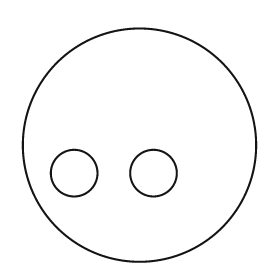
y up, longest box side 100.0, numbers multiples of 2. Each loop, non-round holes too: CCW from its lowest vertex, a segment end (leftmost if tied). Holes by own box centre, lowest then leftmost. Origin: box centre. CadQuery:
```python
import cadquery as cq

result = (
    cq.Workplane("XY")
    .moveTo(0.0, 0.0)
    .circle(50.0)
    .moveTo(-28.0, -12.0)
    .circle(10.0)
    .moveTo(6.0, -12.0)
    .circle(10.0)
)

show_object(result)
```